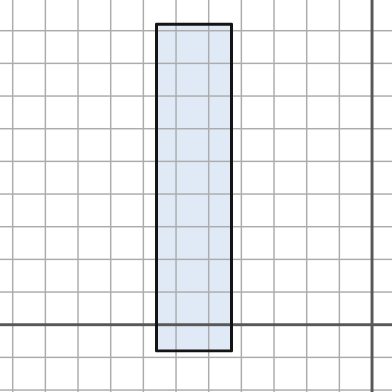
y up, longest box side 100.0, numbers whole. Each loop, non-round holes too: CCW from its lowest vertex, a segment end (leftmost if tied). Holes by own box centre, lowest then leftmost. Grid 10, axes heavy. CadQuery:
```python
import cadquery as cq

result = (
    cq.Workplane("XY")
    .moveTo(-66.0, -8.0)
    .lineTo(-43.0, -8.0)
    .lineTo(-43.0, 92.0)
    .lineTo(-66.0, 92.0)
    .close()
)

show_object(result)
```